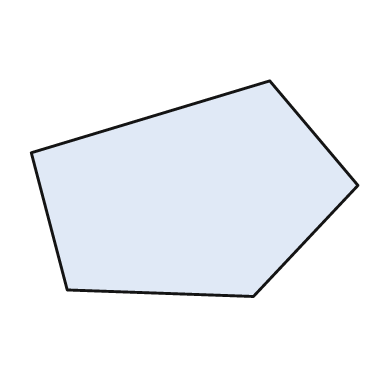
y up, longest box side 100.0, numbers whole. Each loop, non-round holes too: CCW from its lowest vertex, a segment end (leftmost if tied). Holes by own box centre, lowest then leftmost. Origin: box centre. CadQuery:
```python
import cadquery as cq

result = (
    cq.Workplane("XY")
    .moveTo(18.0, -33.0)
    .lineTo(50.0, 1.0)
    .lineTo(23.0, 33.0)
    .lineTo(-50.0, 11.0)
    .lineTo(-39.0, -31.0)
    .close()
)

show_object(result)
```